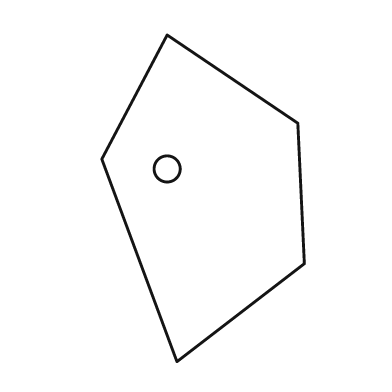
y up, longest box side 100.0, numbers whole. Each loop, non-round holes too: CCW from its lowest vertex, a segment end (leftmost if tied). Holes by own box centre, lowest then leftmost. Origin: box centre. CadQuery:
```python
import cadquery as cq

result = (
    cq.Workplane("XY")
    .moveTo(-8.0, -50.0)
    .lineTo(31.0, -20.0)
    .lineTo(29.0, 23.0)
    .lineTo(-11.0, 50.0)
    .lineTo(-31.0, 12.0)
    .close()
    .moveTo(-11.0, 9.0)
    .circle(4.0)
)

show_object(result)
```